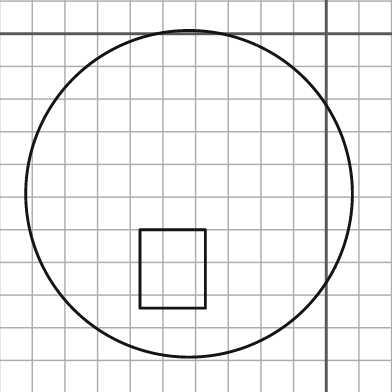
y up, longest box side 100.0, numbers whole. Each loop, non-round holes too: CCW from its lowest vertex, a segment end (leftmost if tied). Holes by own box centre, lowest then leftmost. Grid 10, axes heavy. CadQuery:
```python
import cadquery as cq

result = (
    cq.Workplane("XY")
    .moveTo(-42.0, -49.0)
    .circle(50.0)
    .moveTo(-57.0, -84.0)
    .lineTo(-37.0, -84.0)
    .lineTo(-37.0, -60.0)
    .lineTo(-57.0, -60.0)
    .close()
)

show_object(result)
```